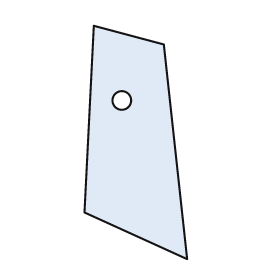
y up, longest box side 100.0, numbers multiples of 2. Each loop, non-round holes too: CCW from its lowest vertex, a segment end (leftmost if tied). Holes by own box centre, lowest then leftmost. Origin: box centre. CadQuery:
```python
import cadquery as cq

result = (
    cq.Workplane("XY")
    .moveTo(22.0, -50.0)
    .lineTo(12.0, 42.0)
    .lineTo(-18.0, 50.0)
    .lineTo(-22.0, -30.0)
    .close()
    .moveTo(-6.0, 18.0)
    .circle(4.0)
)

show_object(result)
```